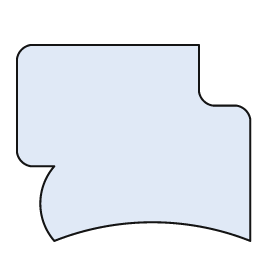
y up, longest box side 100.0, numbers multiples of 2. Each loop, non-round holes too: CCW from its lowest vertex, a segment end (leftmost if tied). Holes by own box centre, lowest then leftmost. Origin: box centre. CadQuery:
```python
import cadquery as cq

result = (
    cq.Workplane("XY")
    .moveTo(-34.0, -42.0)
    .threePointArc((8.0, -34.0), (50.0, -42.0))
    .lineTo(50.0, 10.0)
    .threePointArc((48.0, 14.0), (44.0, 16.0))
    .lineTo(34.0, 16.0)
    .threePointArc((30.0, 18.0), (28.0, 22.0))
    .lineTo(28.0, 42.0)
    .lineTo(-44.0, 42.0)
    .threePointArc((-48.0, 40.0), (-50.0, 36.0))
    .lineTo(-50.0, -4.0)
    .threePointArc((-48.0, -8.0), (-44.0, -10.0))
    .lineTo(-34.0, -10.0)
    .threePointArc((-40.0, -26.0), (-34.0, -42.0))
    .close()
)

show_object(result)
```